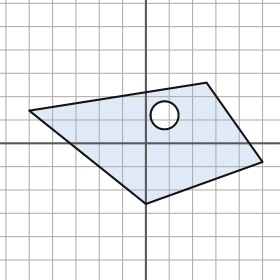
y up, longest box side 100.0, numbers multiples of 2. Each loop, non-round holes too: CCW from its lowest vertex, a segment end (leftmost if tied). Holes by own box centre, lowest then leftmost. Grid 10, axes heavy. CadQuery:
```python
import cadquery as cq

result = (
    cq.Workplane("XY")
    .moveTo(0.0, -26.0)
    .lineTo(50.0, -8.0)
    .lineTo(26.0, 26.0)
    .lineTo(-50.0, 14.0)
    .close()
    .moveTo(8.0, 12.0)
    .circle(6.0)
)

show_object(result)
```